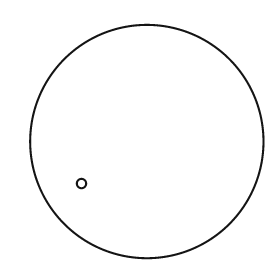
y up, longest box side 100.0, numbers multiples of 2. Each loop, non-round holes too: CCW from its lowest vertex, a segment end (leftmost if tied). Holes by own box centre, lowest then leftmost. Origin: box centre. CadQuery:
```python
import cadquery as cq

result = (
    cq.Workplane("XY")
    .moveTo(0.0, 0.0)
    .circle(50.0)
    .moveTo(-28.0, -18.0)
    .circle(2.0)
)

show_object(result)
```